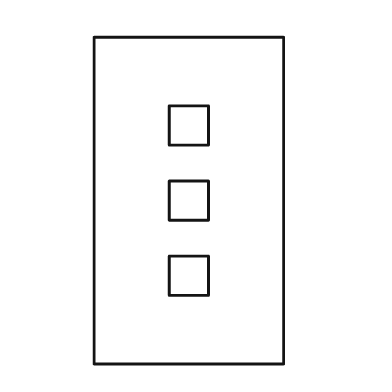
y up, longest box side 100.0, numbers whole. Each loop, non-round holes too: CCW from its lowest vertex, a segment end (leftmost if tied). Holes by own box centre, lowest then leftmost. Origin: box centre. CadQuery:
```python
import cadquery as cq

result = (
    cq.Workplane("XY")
    .moveTo(-29.0, -50.0)
    .lineTo(29.0, -50.0)
    .lineTo(29.0, 50.0)
    .lineTo(-29.0, 50.0)
    .close()
    .moveTo(-6.0, -29.0)
    .lineTo(6.0, -29.0)
    .lineTo(6.0, -17.0)
    .lineTo(-6.0, -17.0)
    .close()
    .moveTo(-6.0, -6.0)
    .lineTo(6.0, -6.0)
    .lineTo(6.0, 6.0)
    .lineTo(-6.0, 6.0)
    .close()
    .moveTo(-6.0, 17.0)
    .lineTo(6.0, 17.0)
    .lineTo(6.0, 29.0)
    .lineTo(-6.0, 29.0)
    .close()
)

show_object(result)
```